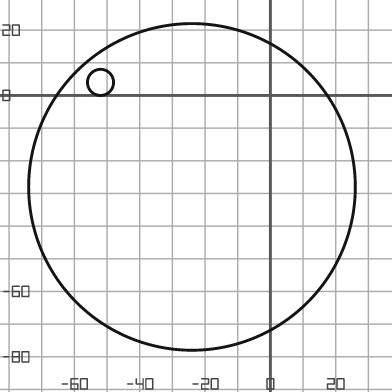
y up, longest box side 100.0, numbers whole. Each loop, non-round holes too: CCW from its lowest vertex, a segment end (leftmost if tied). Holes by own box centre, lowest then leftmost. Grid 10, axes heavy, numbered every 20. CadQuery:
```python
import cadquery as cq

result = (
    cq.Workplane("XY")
    .moveTo(-24.0, -28.0)
    .circle(50.0)
    .moveTo(-52.0, 4.0)
    .circle(4.0)
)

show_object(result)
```